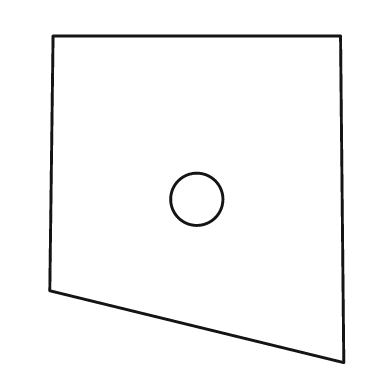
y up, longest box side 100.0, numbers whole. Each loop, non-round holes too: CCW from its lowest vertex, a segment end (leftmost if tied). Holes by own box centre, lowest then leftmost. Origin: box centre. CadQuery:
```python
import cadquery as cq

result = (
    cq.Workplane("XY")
    .moveTo(45.0, -50.0)
    .lineTo(44.0, 50.0)
    .lineTo(-44.0, 50.0)
    .lineTo(-45.0, -28.0)
    .close()
    .moveTo(0.0, 0.0)
    .circle(8.0)
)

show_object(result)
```